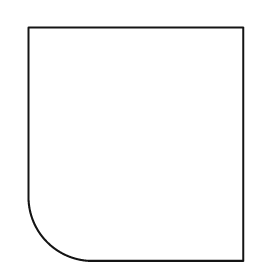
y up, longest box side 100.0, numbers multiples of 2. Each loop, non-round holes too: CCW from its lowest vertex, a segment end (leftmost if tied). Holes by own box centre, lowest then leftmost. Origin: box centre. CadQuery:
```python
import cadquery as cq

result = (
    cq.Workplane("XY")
    .moveTo(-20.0, -50.0)
    .lineTo(46.0, -50.0)
    .lineTo(46.0, 50.0)
    .lineTo(-46.0, 50.0)
    .lineTo(-46.0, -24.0)
    .threePointArc((-38.0, -42.0), (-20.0, -50.0))
    .close()
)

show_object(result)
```